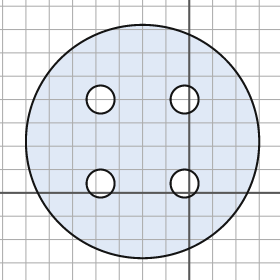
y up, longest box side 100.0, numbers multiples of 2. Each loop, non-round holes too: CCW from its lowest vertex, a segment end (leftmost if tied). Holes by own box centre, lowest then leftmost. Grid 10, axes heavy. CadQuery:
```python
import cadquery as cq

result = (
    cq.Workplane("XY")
    .moveTo(-20.0, 22.0)
    .circle(50.0)
    .moveTo(-38.0, 4.0)
    .circle(6.0)
    .moveTo(-2.0, 4.0)
    .circle(6.0)
    .moveTo(-38.0, 40.0)
    .circle(6.0)
    .moveTo(-2.0, 40.0)
    .circle(6.0)
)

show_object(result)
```